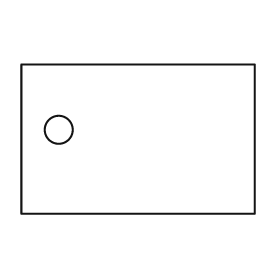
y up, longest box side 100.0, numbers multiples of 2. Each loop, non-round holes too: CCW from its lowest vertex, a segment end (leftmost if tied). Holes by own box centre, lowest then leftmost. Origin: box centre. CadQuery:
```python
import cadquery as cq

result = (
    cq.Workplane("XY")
    .moveTo(-50.0, -32.0)
    .lineTo(50.0, -32.0)
    .lineTo(50.0, 32.0)
    .lineTo(-50.0, 32.0)
    .close()
    .moveTo(-34.0, 4.0)
    .circle(6.0)
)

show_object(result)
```